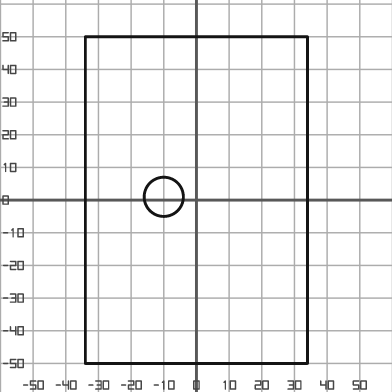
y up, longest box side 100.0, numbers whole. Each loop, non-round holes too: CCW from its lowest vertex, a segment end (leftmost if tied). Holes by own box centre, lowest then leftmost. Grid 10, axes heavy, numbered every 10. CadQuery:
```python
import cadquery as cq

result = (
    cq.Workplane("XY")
    .moveTo(-34.0, -50.0)
    .lineTo(34.0, -50.0)
    .lineTo(34.0, 50.0)
    .lineTo(-34.0, 50.0)
    .close()
    .moveTo(-10.0, 1.0)
    .circle(6.0)
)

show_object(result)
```